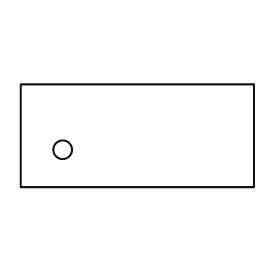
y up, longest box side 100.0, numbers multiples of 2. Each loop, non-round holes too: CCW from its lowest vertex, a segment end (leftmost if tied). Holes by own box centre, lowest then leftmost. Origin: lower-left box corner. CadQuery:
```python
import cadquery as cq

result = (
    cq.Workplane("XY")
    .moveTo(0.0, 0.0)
    .lineTo(100.0, 0.0)
    .lineTo(100.0, 44.0)
    .lineTo(0.0, 44.0)
    .close()
    .moveTo(18.0, 16.0)
    .circle(4.0)
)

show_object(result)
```